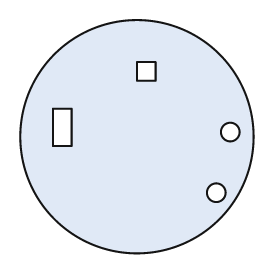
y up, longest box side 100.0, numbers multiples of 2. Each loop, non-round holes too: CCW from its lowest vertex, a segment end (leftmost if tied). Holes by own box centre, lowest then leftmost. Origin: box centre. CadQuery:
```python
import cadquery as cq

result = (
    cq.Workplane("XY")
    .moveTo(0.0, 0.0)
    .circle(50.0)
    .moveTo(34.0, -24.0)
    .circle(4.0)
    .moveTo(40.0, 2.0)
    .circle(4.0)
    .moveTo(-36.0, -4.0)
    .lineTo(-28.0, -4.0)
    .lineTo(-28.0, 12.0)
    .lineTo(-36.0, 12.0)
    .close()
    .moveTo(0.0, 24.0)
    .lineTo(8.0, 24.0)
    .lineTo(8.0, 32.0)
    .lineTo(0.0, 32.0)
    .close()
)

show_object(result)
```